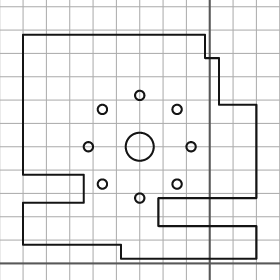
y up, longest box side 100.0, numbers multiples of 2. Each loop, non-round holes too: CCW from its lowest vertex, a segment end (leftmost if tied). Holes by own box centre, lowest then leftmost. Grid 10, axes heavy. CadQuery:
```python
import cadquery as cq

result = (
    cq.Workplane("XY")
    .moveTo(-38.0, 2.0)
    .lineTo(20.0, 2.0)
    .lineTo(20.0, 16.0)
    .lineTo(-22.0, 16.0)
    .lineTo(-22.0, 28.0)
    .lineTo(20.0, 28.0)
    .lineTo(20.0, 68.0)
    .lineTo(4.0, 68.0)
    .lineTo(4.0, 88.0)
    .lineTo(-2.0, 88.0)
    .lineTo(-2.0, 98.0)
    .lineTo(-80.0, 98.0)
    .lineTo(-80.0, 38.0)
    .lineTo(-54.0, 38.0)
    .lineTo(-54.0, 26.0)
    .lineTo(-80.0, 26.0)
    .lineTo(-80.0, 8.0)
    .lineTo(-38.0, 8.0)
    .close()
    .moveTo(-30.0, 28.0)
    .circle(2.0)
    .moveTo(-46.0, 34.0)
    .circle(2.0)
    .moveTo(-14.0, 34.0)
    .circle(2.0)
    .moveTo(-52.0, 50.0)
    .circle(2.0)
    .moveTo(-30.0, 50.0)
    .circle(6.0)
    .moveTo(-8.0, 50.0)
    .circle(2.0)
    .moveTo(-46.0, 66.0)
    .circle(2.0)
    .moveTo(-14.0, 66.0)
    .circle(2.0)
    .moveTo(-30.0, 72.0)
    .circle(2.0)
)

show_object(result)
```